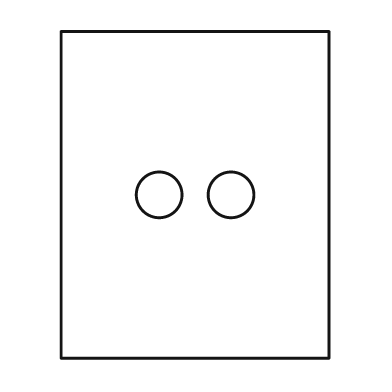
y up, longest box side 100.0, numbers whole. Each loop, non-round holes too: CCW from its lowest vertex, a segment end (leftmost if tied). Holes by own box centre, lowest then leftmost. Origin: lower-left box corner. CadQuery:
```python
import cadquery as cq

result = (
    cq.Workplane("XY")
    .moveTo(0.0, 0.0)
    .lineTo(82.0, 0.0)
    .lineTo(82.0, 100.0)
    .lineTo(0.0, 100.0)
    .close()
    .moveTo(30.0, 50.0)
    .circle(7.0)
    .moveTo(52.0, 50.0)
    .circle(7.0)
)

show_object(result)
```